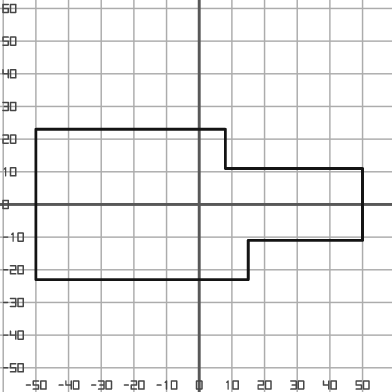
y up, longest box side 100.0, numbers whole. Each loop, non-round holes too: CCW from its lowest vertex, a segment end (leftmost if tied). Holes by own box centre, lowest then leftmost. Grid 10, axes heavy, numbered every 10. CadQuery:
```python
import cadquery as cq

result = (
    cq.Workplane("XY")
    .moveTo(-50.0, -23.0)
    .lineTo(15.0, -23.0)
    .lineTo(15.0, -11.0)
    .lineTo(50.0, -11.0)
    .lineTo(50.0, 11.0)
    .lineTo(8.0, 11.0)
    .lineTo(8.0, 23.0)
    .lineTo(-50.0, 23.0)
    .close()
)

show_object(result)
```